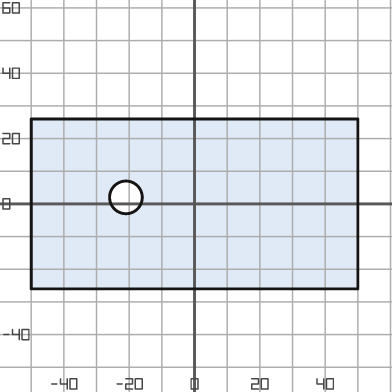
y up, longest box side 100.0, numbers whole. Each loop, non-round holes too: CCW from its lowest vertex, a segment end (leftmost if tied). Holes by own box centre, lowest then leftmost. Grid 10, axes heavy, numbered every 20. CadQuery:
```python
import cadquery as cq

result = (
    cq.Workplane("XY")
    .moveTo(-50.0, -26.0)
    .lineTo(50.0, -26.0)
    .lineTo(50.0, 26.0)
    .lineTo(-50.0, 26.0)
    .close()
    .moveTo(-21.0, 2.0)
    .circle(5.0)
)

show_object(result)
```